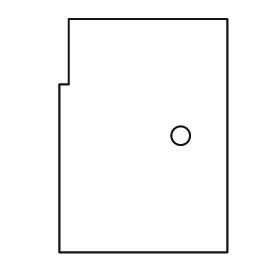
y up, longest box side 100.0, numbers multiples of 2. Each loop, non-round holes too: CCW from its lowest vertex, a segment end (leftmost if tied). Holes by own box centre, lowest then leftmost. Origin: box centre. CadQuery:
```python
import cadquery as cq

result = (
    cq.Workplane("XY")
    .moveTo(-36.0, -50.0)
    .lineTo(36.0, -50.0)
    .lineTo(36.0, 50.0)
    .lineTo(-32.0, 50.0)
    .lineTo(-32.0, 22.0)
    .lineTo(-36.0, 22.0)
    .close()
    .moveTo(16.0, 0.0)
    .circle(4.0)
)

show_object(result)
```